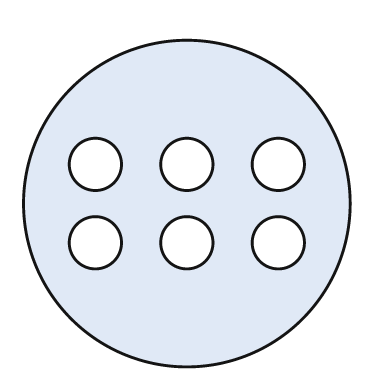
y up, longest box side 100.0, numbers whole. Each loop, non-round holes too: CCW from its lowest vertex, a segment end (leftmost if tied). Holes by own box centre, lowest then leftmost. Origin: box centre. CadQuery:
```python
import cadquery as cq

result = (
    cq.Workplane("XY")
    .moveTo(0.0, 0.0)
    .circle(50.0)
    .moveTo(-28.0, -12.0)
    .circle(8.0)
    .moveTo(0.0, -12.0)
    .circle(8.0)
    .moveTo(28.0, -12.0)
    .circle(8.0)
    .moveTo(-28.0, 12.0)
    .circle(8.0)
    .moveTo(0.0, 12.0)
    .circle(8.0)
    .moveTo(28.0, 12.0)
    .circle(8.0)
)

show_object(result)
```